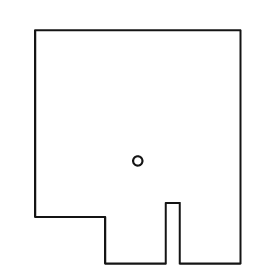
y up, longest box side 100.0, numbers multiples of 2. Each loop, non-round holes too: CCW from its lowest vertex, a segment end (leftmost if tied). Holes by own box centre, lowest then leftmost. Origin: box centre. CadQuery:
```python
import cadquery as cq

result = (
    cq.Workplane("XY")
    .moveTo(-14.0, -50.0)
    .lineTo(12.0, -50.0)
    .lineTo(12.0, -24.0)
    .lineTo(18.0, -24.0)
    .lineTo(18.0, -50.0)
    .lineTo(44.0, -50.0)
    .lineTo(44.0, 50.0)
    .lineTo(-44.0, 50.0)
    .lineTo(-44.0, -30.0)
    .lineTo(-14.0, -30.0)
    .close()
    .moveTo(0.0, -6.0)
    .circle(2.0)
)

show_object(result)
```